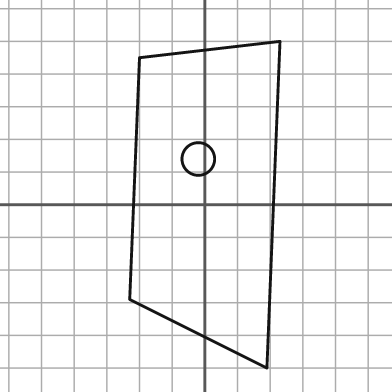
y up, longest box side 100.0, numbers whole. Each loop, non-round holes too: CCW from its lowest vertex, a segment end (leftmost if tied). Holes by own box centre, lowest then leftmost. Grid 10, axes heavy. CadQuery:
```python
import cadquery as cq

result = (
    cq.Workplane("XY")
    .moveTo(19.0, -50.0)
    .lineTo(23.0, 50.0)
    .lineTo(-20.0, 45.0)
    .lineTo(-23.0, -29.0)
    .close()
    .moveTo(-2.0, 14.0)
    .circle(5.0)
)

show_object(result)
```